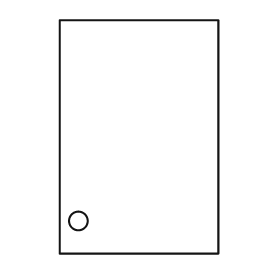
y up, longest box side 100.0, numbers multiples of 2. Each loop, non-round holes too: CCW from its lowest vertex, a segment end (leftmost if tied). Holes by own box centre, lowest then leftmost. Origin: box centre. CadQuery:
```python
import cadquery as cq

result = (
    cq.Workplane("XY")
    .moveTo(-34.0, -50.0)
    .lineTo(34.0, -50.0)
    .lineTo(34.0, 50.0)
    .lineTo(-34.0, 50.0)
    .close()
    .moveTo(-26.0, -36.0)
    .circle(4.0)
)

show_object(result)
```